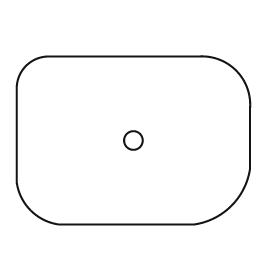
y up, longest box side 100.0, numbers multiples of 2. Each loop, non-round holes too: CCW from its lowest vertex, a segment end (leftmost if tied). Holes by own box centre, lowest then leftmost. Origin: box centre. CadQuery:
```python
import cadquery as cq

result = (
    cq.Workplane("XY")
    .moveTo(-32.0, -36.0)
    .lineTo(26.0, -36.0)
    .threePointArc((42.0, -28.0), (50.0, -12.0))
    .lineTo(50.0, 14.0)
    .threePointArc((44.0, 30.0), (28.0, 36.0))
    .lineTo(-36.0, 36.0)
    .threePointArc((-46.0, 32.0), (-50.0, 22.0))
    .lineTo(-50.0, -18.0)
    .threePointArc((-44.0, -30.0), (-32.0, -36.0))
    .close()
    .moveTo(0.0, 0.0)
    .circle(4.0)
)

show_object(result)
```